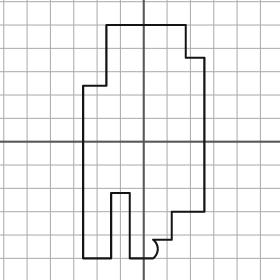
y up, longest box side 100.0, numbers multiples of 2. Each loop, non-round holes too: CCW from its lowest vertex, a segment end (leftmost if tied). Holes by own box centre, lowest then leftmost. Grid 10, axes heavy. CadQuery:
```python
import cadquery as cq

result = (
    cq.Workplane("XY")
    .moveTo(-26.0, -50.0)
    .lineTo(-14.0, -50.0)
    .lineTo(-14.0, -22.0)
    .lineTo(-6.0, -22.0)
    .lineTo(-6.0, -50.0)
    .lineTo(4.0, -50.0)
    .threePointArc((6.0, -46.0), (4.0, -42.0))
    .lineTo(12.0, -42.0)
    .lineTo(12.0, -30.0)
    .lineTo(26.0, -30.0)
    .lineTo(26.0, 36.0)
    .lineTo(18.0, 36.0)
    .lineTo(18.0, 50.0)
    .lineTo(-16.0, 50.0)
    .lineTo(-16.0, 24.0)
    .lineTo(-26.0, 24.0)
    .close()
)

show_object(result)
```